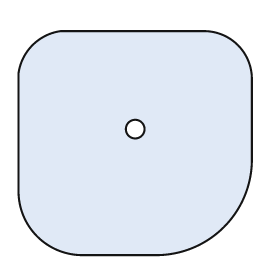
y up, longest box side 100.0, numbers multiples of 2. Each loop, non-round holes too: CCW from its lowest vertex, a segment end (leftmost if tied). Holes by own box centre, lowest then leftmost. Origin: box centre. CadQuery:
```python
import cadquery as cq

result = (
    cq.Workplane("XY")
    .moveTo(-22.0, -48.0)
    .lineTo(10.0, -48.0)
    .threePointArc((38.0, -36.0), (50.0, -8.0))
    .lineTo(50.0, 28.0)
    .threePointArc((44.0, 42.0), (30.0, 48.0))
    .lineTo(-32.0, 48.0)
    .threePointArc((-44.0, 42.0), (-50.0, 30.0))
    .lineTo(-50.0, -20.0)
    .threePointArc((-42.0, -40.0), (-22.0, -48.0))
    .close()
    .moveTo(0.0, 6.0)
    .circle(4.0)
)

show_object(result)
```